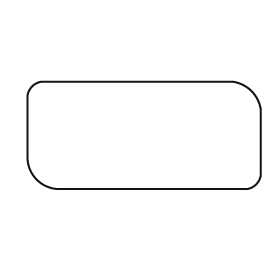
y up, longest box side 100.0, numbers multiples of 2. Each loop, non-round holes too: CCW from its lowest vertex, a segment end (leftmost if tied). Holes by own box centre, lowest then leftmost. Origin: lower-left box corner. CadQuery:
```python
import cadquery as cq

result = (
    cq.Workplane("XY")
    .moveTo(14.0, 0.0)
    .lineTo(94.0, 0.0)
    .threePointArc((98.0, 2.0), (100.0, 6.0))
    .lineTo(100.0, 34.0)
    .threePointArc((96.0, 42.0), (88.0, 46.0))
    .lineTo(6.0, 46.0)
    .threePointArc((2.0, 44.0), (0.0, 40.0))
    .lineTo(0.0, 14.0)
    .threePointArc((4.0, 4.0), (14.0, 0.0))
    .close()
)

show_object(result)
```